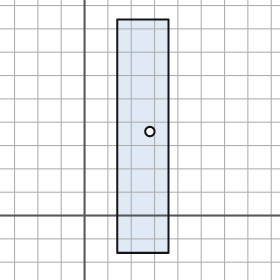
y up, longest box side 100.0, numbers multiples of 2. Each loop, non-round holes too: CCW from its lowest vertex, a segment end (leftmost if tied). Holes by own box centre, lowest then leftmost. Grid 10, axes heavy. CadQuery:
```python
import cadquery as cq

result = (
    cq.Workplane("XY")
    .moveTo(14.0, -16.0)
    .lineTo(36.0, -16.0)
    .lineTo(36.0, 84.0)
    .lineTo(14.0, 84.0)
    .close()
    .moveTo(28.0, 36.0)
    .circle(2.0)
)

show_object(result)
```